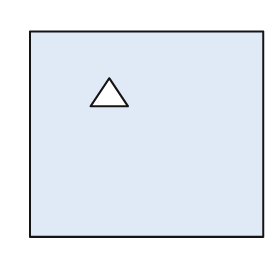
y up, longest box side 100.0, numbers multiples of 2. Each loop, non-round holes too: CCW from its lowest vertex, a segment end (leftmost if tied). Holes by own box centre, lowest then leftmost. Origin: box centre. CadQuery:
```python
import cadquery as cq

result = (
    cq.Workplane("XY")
    .moveTo(-50.0, -44.0)
    .lineTo(50.0, -44.0)
    .lineTo(50.0, 44.0)
    .lineTo(-50.0, 44.0)
    .close()
    .moveTo(-24.0, 12.0)
    .lineTo(-8.0, 12.0)
    .lineTo(-16.0, 24.0)
    .close()
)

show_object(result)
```